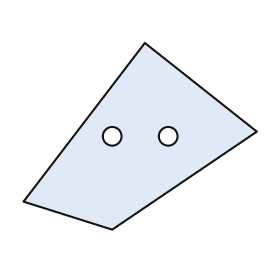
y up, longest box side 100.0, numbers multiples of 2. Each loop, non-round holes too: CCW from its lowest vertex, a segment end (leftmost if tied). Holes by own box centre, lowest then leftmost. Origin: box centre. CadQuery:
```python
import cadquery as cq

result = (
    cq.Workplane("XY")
    .moveTo(-12.0, -40.0)
    .lineTo(50.0, 2.0)
    .lineTo(2.0, 40.0)
    .lineTo(-50.0, -28.0)
    .close()
    .moveTo(-12.0, 0.0)
    .circle(4.0)
    .moveTo(12.0, 0.0)
    .circle(4.0)
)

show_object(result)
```